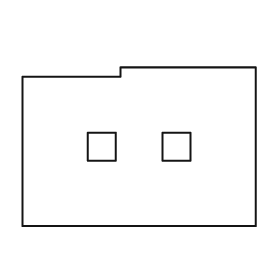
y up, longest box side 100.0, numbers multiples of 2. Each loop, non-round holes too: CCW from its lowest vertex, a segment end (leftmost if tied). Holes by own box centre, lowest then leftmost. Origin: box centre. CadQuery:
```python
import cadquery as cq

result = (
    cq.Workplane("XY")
    .moveTo(-50.0, -34.0)
    .lineTo(50.0, -34.0)
    .lineTo(50.0, 34.0)
    .lineTo(-8.0, 34.0)
    .lineTo(-8.0, 30.0)
    .lineTo(-50.0, 30.0)
    .close()
    .moveTo(-22.0, -6.0)
    .lineTo(-10.0, -6.0)
    .lineTo(-10.0, 6.0)
    .lineTo(-22.0, 6.0)
    .close()
    .moveTo(10.0, -6.0)
    .lineTo(22.0, -6.0)
    .lineTo(22.0, 6.0)
    .lineTo(10.0, 6.0)
    .close()
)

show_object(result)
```